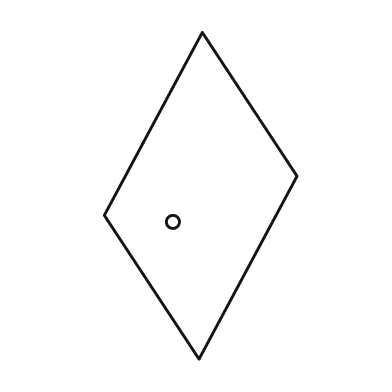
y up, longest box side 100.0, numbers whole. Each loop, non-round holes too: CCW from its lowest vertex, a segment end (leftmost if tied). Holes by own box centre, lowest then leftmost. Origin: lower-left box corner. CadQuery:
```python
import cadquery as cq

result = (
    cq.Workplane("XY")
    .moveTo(29.0, 0.0)
    .lineTo(59.0, 56.0)
    .lineTo(30.0, 100.0)
    .lineTo(0.0, 44.0)
    .close()
    .moveTo(21.0, 42.0)
    .circle(2.0)
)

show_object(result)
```